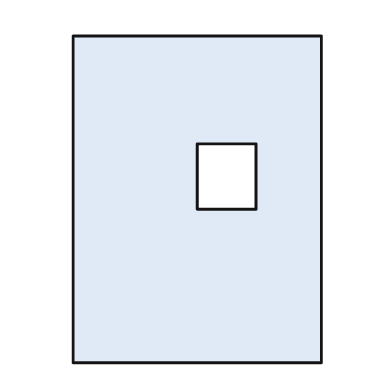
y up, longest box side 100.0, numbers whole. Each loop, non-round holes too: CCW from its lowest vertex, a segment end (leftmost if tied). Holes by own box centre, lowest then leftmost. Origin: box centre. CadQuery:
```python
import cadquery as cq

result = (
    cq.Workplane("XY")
    .moveTo(-38.0, -50.0)
    .lineTo(38.0, -50.0)
    .lineTo(38.0, 50.0)
    .lineTo(-38.0, 50.0)
    .close()
    .moveTo(0.0, -3.0)
    .lineTo(18.0, -3.0)
    .lineTo(18.0, 17.0)
    .lineTo(0.0, 17.0)
    .close()
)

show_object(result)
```